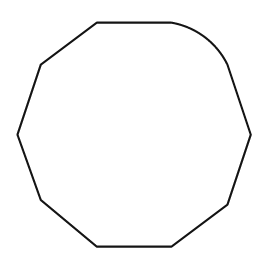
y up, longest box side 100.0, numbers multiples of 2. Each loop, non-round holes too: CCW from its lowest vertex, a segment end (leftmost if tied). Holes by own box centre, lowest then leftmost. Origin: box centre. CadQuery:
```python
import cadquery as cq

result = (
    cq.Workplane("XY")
    .moveTo(-16.0, -48.0)
    .lineTo(16.0, -48.0)
    .lineTo(40.0, -30.0)
    .lineTo(50.0, 0.0)
    .lineTo(40.0, 30.0)
    .threePointArc((30.0, 42.0), (16.0, 48.0))
    .lineTo(-16.0, 48.0)
    .lineTo(-40.0, 30.0)
    .lineTo(-50.0, 0.0)
    .lineTo(-40.0, -28.0)
    .close()
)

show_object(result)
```